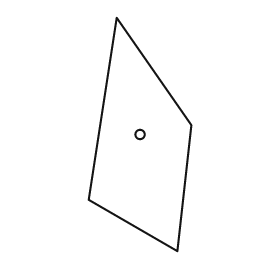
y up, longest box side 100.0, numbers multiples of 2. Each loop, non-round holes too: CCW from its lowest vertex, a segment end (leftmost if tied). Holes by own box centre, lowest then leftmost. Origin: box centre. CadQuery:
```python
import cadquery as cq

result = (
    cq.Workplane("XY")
    .moveTo(16.0, -50.0)
    .lineTo(22.0, 4.0)
    .lineTo(-10.0, 50.0)
    .lineTo(-22.0, -28.0)
    .close()
    .moveTo(0.0, 0.0)
    .circle(2.0)
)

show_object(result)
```